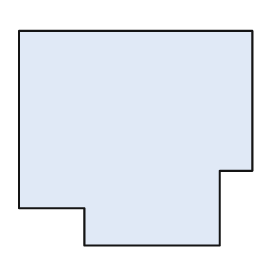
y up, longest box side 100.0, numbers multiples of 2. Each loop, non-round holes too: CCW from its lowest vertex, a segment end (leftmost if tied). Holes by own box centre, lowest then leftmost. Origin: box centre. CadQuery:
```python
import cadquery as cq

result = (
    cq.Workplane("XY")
    .moveTo(-22.0, -46.0)
    .lineTo(36.0, -46.0)
    .lineTo(36.0, -14.0)
    .lineTo(50.0, -14.0)
    .lineTo(50.0, 46.0)
    .lineTo(-50.0, 46.0)
    .lineTo(-50.0, -30.0)
    .lineTo(-22.0, -30.0)
    .close()
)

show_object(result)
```